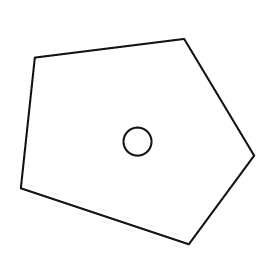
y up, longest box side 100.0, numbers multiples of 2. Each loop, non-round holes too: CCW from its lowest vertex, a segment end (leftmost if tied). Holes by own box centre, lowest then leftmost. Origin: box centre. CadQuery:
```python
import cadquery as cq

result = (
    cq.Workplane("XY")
    .moveTo(22.0, -44.0)
    .lineTo(50.0, -6.0)
    .lineTo(20.0, 44.0)
    .lineTo(-44.0, 36.0)
    .lineTo(-50.0, -20.0)
    .close()
    .moveTo(0.0, 0.0)
    .circle(6.0)
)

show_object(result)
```